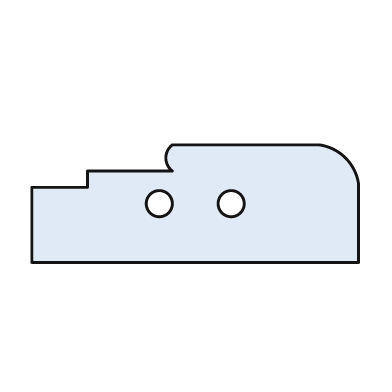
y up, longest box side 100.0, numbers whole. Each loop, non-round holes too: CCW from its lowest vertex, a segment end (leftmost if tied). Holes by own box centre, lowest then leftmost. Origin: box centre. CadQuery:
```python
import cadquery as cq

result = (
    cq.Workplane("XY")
    .moveTo(-50.0, -18.0)
    .lineTo(50.0, -18.0)
    .lineTo(50.0, 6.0)
    .threePointArc((46.0, 14.0), (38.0, 18.0))
    .lineTo(-7.0, 18.0)
    .threePointArc((-9.0, 14.0), (-7.0, 10.0))
    .lineTo(-33.0, 10.0)
    .lineTo(-33.0, 5.0)
    .lineTo(-50.0, 5.0)
    .close()
    .moveTo(-11.0, 0.0)
    .circle(4.0)
    .moveTo(11.0, 0.0)
    .circle(4.0)
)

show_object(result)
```